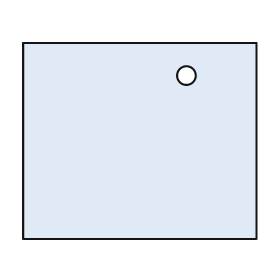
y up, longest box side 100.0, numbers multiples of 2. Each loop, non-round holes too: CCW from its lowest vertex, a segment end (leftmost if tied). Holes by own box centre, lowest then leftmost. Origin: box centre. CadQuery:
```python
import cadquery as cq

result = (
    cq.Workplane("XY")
    .moveTo(-50.0, -42.0)
    .lineTo(50.0, -42.0)
    .lineTo(50.0, 42.0)
    .lineTo(-50.0, 42.0)
    .close()
    .moveTo(20.0, 28.0)
    .circle(4.0)
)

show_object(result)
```